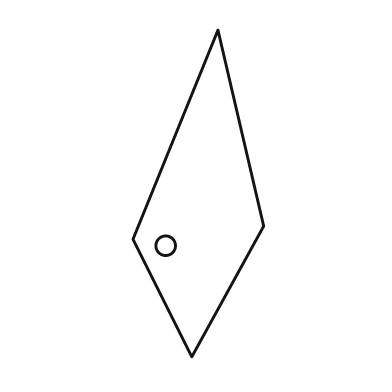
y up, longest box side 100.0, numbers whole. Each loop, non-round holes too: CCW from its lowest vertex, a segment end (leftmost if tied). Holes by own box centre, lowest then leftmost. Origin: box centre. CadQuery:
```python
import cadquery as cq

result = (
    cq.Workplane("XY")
    .moveTo(-2.0, -50.0)
    .lineTo(20.0, -10.0)
    .lineTo(6.0, 50.0)
    .lineTo(-20.0, -14.0)
    .close()
    .moveTo(-10.0, -16.0)
    .circle(3.0)
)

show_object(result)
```